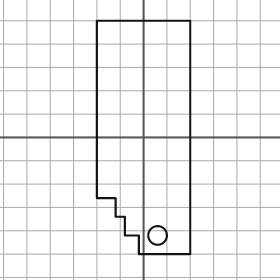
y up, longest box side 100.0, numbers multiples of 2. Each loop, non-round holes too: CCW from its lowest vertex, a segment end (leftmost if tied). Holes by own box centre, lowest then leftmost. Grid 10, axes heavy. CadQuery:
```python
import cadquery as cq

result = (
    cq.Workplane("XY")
    .moveTo(-2.0, -50.0)
    .lineTo(20.0, -50.0)
    .lineTo(20.0, 50.0)
    .lineTo(-20.0, 50.0)
    .lineTo(-20.0, -26.0)
    .lineTo(-12.0, -26.0)
    .lineTo(-12.0, -34.0)
    .lineTo(-8.0, -34.0)
    .lineTo(-8.0, -42.0)
    .lineTo(-2.0, -42.0)
    .close()
    .moveTo(6.0, -42.0)
    .circle(4.0)
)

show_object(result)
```